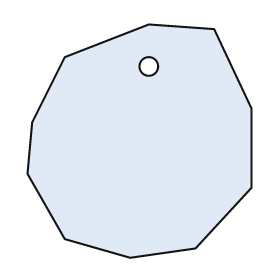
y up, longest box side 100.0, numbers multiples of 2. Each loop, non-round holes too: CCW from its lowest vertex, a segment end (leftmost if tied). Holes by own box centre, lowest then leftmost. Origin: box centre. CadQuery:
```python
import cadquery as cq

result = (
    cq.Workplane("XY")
    .moveTo(-4.0, -50.0)
    .lineTo(24.0, -46.0)
    .lineTo(48.0, -20.0)
    .lineTo(48.0, 14.0)
    .lineTo(32.0, 48.0)
    .lineTo(4.0, 50.0)
    .lineTo(-32.0, 36.0)
    .lineTo(-46.0, 8.0)
    .lineTo(-48.0, -14.0)
    .lineTo(-32.0, -42.0)
    .close()
    .moveTo(4.0, 32.0)
    .circle(4.0)
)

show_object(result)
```